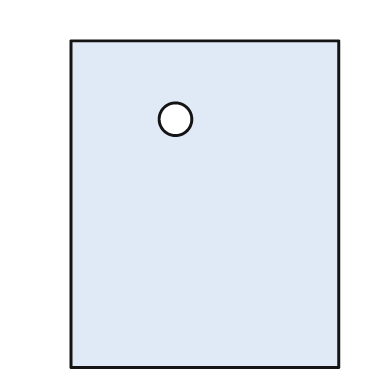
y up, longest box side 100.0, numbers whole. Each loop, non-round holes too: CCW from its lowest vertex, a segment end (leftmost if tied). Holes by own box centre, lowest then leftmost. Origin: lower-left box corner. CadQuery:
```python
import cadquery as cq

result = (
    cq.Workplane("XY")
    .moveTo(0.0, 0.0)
    .lineTo(82.0, 0.0)
    .lineTo(82.0, 100.0)
    .lineTo(0.0, 100.0)
    .close()
    .moveTo(32.0, 76.0)
    .circle(5.0)
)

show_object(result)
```